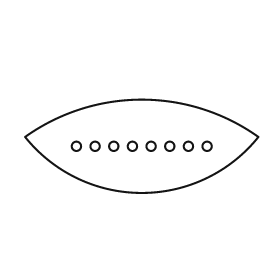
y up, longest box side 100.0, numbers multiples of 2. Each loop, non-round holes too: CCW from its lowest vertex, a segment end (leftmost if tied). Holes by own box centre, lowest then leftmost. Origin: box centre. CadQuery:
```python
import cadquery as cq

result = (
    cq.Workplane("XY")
    .moveTo(-50.0, 4.0)
    .threePointArc((0.0, -20.0), (50.0, 4.0))
    .threePointArc((0.0, 20.0), (-50.0, 4.0))
    .close()
    .moveTo(-28.0, 0.0)
    .circle(2.0)
    .moveTo(-20.0, 0.0)
    .circle(2.0)
    .moveTo(-12.0, 0.0)
    .circle(2.0)
    .moveTo(-4.0, 0.0)
    .circle(2.0)
    .moveTo(4.0, 0.0)
    .circle(2.0)
    .moveTo(12.0, 0.0)
    .circle(2.0)
    .moveTo(20.0, 0.0)
    .circle(2.0)
    .moveTo(28.0, 0.0)
    .circle(2.0)
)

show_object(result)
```